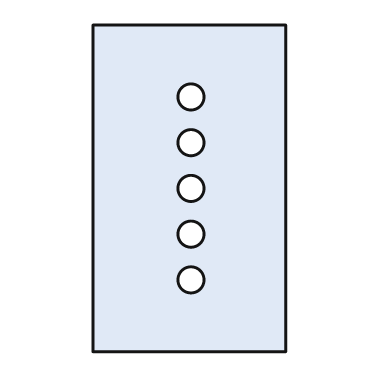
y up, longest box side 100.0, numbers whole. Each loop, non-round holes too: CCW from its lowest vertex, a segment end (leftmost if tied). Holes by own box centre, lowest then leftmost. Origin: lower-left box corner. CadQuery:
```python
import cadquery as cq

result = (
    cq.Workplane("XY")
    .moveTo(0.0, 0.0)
    .lineTo(59.0, 0.0)
    .lineTo(59.0, 100.0)
    .lineTo(0.0, 100.0)
    .close()
    .moveTo(30.0, 22.0)
    .circle(4.0)
    .moveTo(30.0, 36.0)
    .circle(4.0)
    .moveTo(30.0, 50.0)
    .circle(4.0)
    .moveTo(30.0, 64.0)
    .circle(4.0)
    .moveTo(30.0, 78.0)
    .circle(4.0)
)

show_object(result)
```